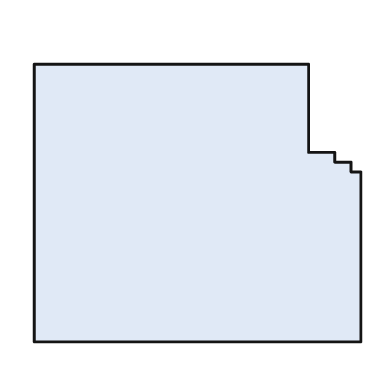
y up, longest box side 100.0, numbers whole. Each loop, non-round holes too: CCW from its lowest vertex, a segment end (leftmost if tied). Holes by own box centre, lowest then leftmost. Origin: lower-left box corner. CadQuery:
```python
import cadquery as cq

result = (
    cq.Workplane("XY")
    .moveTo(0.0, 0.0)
    .lineTo(100.0, 0.0)
    .lineTo(100.0, 52.0)
    .lineTo(97.0, 52.0)
    .lineTo(97.0, 55.0)
    .lineTo(92.0, 55.0)
    .lineTo(92.0, 58.0)
    .lineTo(84.0, 58.0)
    .lineTo(84.0, 85.0)
    .lineTo(0.0, 85.0)
    .close()
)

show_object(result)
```